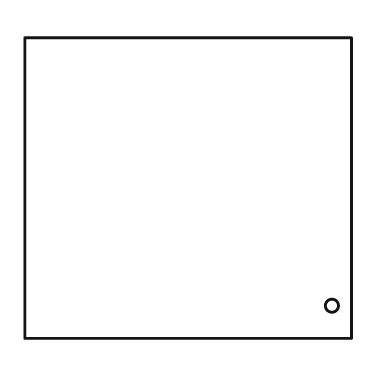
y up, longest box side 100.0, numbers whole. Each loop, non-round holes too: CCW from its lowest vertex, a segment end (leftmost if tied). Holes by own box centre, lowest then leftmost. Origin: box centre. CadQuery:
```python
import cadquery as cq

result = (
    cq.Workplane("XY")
    .moveTo(-50.0, -46.0)
    .lineTo(50.0, -46.0)
    .lineTo(50.0, 46.0)
    .lineTo(-50.0, 46.0)
    .close()
    .moveTo(44.0, -36.0)
    .circle(2.0)
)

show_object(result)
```